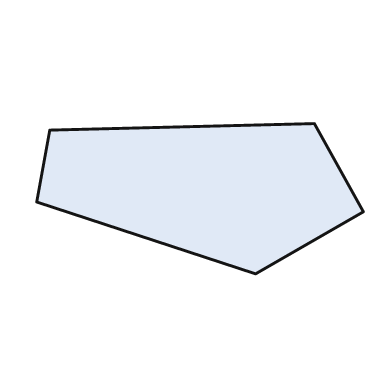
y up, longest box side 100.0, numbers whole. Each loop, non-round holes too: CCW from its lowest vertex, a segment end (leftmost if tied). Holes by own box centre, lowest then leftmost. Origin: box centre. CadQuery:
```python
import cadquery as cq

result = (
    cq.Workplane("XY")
    .moveTo(17.0, -23.0)
    .lineTo(50.0, -4.0)
    .lineTo(35.0, 23.0)
    .lineTo(-46.0, 21.0)
    .lineTo(-50.0, -1.0)
    .close()
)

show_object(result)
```